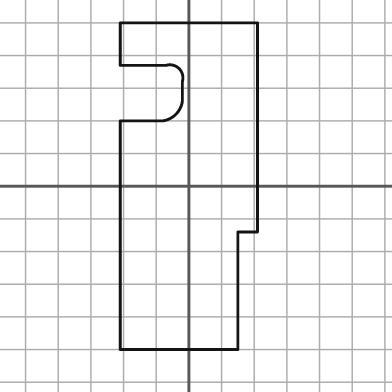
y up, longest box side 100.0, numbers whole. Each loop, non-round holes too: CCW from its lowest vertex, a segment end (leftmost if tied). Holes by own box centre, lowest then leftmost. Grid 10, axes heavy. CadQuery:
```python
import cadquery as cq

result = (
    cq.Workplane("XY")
    .moveTo(-21.0, -50.0)
    .lineTo(15.0, -50.0)
    .lineTo(15.0, -14.0)
    .lineTo(21.0, -14.0)
    .lineTo(21.0, 50.0)
    .lineTo(-21.0, 50.0)
    .lineTo(-21.0, 37.0)
    .lineTo(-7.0, 37.0)
    .threePointArc((-3.0, 36.0), (-2.0, 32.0))
    .lineTo(-2.0, 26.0)
    .threePointArc((-4.0, 22.0), (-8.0, 20.0))
    .lineTo(-21.0, 20.0)
    .close()
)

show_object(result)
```